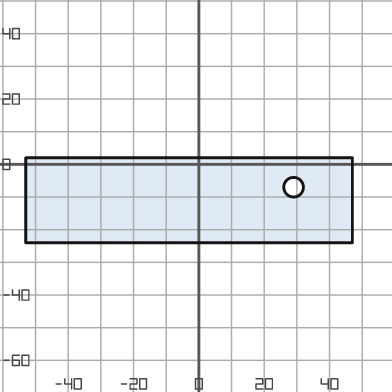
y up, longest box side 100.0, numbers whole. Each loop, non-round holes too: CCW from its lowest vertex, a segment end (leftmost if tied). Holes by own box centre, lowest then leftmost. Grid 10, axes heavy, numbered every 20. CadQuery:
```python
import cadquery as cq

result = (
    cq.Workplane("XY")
    .moveTo(-53.0, -24.0)
    .lineTo(47.0, -24.0)
    .lineTo(47.0, 2.0)
    .lineTo(-53.0, 2.0)
    .close()
    .moveTo(29.0, -7.0)
    .circle(3.0)
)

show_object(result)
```